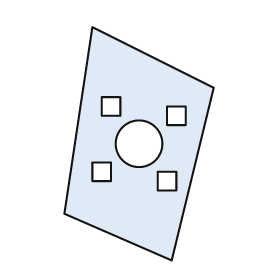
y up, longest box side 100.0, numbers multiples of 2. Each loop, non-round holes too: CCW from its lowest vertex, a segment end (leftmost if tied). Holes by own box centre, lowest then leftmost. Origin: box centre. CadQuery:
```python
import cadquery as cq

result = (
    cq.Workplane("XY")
    .moveTo(14.0, -50.0)
    .lineTo(32.0, 24.0)
    .lineTo(-20.0, 50.0)
    .lineTo(-32.0, -30.0)
    .close()
    .moveTo(8.0, -20.0)
    .lineTo(16.0, -20.0)
    .lineTo(16.0, -12.0)
    .lineTo(8.0, -12.0)
    .close()
    .moveTo(-20.0, -16.0)
    .lineTo(-12.0, -16.0)
    .lineTo(-12.0, -8.0)
    .lineTo(-20.0, -8.0)
    .close()
    .moveTo(0.0, 0.0)
    .circle(10.0)
    .moveTo(12.0, 8.0)
    .lineTo(20.0, 8.0)
    .lineTo(20.0, 16.0)
    .lineTo(12.0, 16.0)
    .close()
    .moveTo(-16.0, 12.0)
    .lineTo(-8.0, 12.0)
    .lineTo(-8.0, 20.0)
    .lineTo(-16.0, 20.0)
    .close()
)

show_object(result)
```